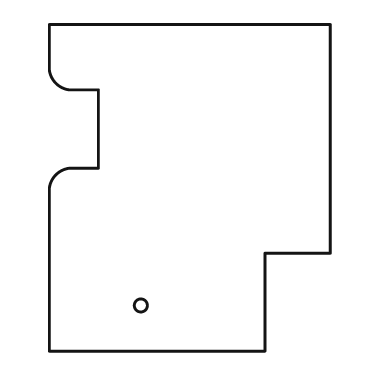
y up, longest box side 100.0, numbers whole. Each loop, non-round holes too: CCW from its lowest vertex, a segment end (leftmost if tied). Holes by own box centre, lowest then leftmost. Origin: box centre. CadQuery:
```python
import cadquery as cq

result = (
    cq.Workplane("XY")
    .moveTo(-43.0, -50.0)
    .lineTo(23.0, -50.0)
    .lineTo(23.0, -20.0)
    .lineTo(43.0, -20.0)
    .lineTo(43.0, 50.0)
    .lineTo(-43.0, 50.0)
    .lineTo(-43.0, 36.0)
    .threePointArc((-41.0, 32.0), (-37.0, 30.0))
    .lineTo(-28.0, 30.0)
    .lineTo(-28.0, 6.0)
    .lineTo(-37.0, 6.0)
    .threePointArc((-41.0, 4.0), (-43.0, 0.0))
    .close()
    .moveTo(-15.0, -36.0)
    .circle(2.0)
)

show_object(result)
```